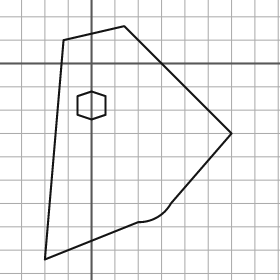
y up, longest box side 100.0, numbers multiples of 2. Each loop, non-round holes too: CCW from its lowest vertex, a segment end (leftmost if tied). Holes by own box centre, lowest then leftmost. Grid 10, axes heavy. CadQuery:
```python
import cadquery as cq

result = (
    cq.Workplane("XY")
    .moveTo(-20.0, -84.0)
    .lineTo(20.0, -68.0)
    .threePointArc((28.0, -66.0), (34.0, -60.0))
    .lineTo(60.0, -30.0)
    .lineTo(14.0, 16.0)
    .lineTo(-12.0, 10.0)
    .close()
    .moveTo(0.0, -24.0)
    .lineTo(6.0, -22.0)
    .lineTo(6.0, -14.0)
    .lineTo(0.0, -12.0)
    .lineTo(-6.0, -14.0)
    .lineTo(-6.0, -22.0)
    .close()
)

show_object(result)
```